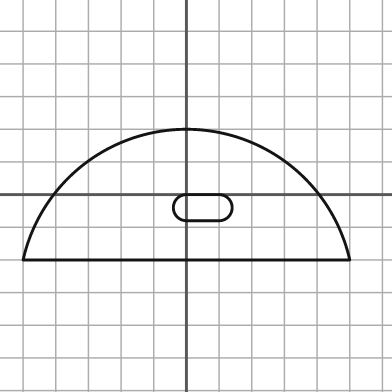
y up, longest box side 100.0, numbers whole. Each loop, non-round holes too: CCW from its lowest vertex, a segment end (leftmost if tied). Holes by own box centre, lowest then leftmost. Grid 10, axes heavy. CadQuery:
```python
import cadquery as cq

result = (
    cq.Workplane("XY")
    .moveTo(-50.0, -20.0)
    .lineTo(50.0, -20.0)
    .threePointArc((0.0, 20.0), (-50.0, -20.0))
    .close()
    .moveTo(0.0, -8.0)
    .lineTo(10.0, -8.0)
    .threePointArc((14.0, -4.0), (10.0, 0.0))
    .lineTo(0.0, 0.0)
    .threePointArc((-4.0, -4.0), (0.0, -8.0))
    .close()
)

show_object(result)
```